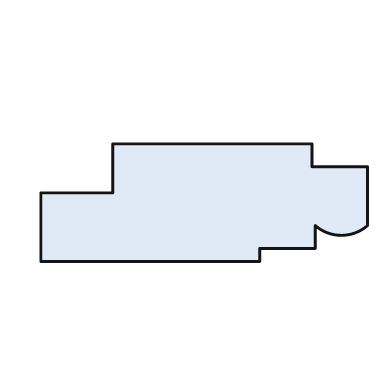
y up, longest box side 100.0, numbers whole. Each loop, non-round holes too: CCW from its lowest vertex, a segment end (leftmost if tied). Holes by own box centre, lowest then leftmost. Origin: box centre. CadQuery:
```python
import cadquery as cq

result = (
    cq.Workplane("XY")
    .moveTo(-50.0, -18.0)
    .lineTo(17.0, -18.0)
    .lineTo(17.0, -14.0)
    .lineTo(34.0, -14.0)
    .lineTo(34.0, -7.0)
    .threePointArc((42.0, -10.0), (50.0, -7.0))
    .lineTo(50.0, 11.0)
    .lineTo(33.0, 11.0)
    .lineTo(33.0, 18.0)
    .lineTo(-28.0, 18.0)
    .lineTo(-28.0, 3.0)
    .lineTo(-50.0, 3.0)
    .close()
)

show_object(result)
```